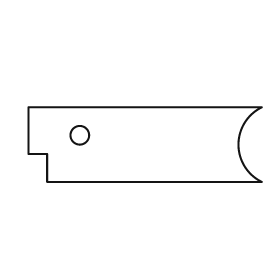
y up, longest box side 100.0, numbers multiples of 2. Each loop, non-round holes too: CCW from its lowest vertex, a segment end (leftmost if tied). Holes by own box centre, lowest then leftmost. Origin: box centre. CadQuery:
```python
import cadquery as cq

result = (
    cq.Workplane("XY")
    .moveTo(-42.0, -16.0)
    .lineTo(50.0, -16.0)
    .threePointArc((40.0, 0.0), (50.0, 16.0))
    .lineTo(-50.0, 16.0)
    .lineTo(-50.0, -4.0)
    .lineTo(-42.0, -4.0)
    .close()
    .moveTo(-28.0, 4.0)
    .circle(4.0)
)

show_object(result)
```